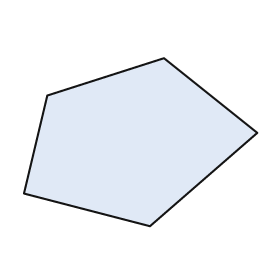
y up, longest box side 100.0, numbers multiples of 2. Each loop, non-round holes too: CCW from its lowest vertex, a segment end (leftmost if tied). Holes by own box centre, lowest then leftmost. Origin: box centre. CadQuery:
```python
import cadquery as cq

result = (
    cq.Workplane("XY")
    .moveTo(4.0, -36.0)
    .lineTo(50.0, 4.0)
    .lineTo(10.0, 36.0)
    .lineTo(-40.0, 20.0)
    .lineTo(-50.0, -22.0)
    .close()
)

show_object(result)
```